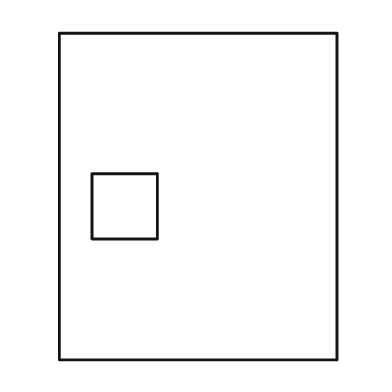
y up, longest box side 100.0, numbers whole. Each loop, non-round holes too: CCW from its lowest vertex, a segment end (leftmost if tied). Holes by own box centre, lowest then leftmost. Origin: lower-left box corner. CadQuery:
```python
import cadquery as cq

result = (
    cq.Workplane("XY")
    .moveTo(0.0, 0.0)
    .lineTo(85.0, 0.0)
    .lineTo(85.0, 100.0)
    .lineTo(0.0, 100.0)
    .close()
    .moveTo(10.0, 37.0)
    .lineTo(30.0, 37.0)
    .lineTo(30.0, 57.0)
    .lineTo(10.0, 57.0)
    .close()
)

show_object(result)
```